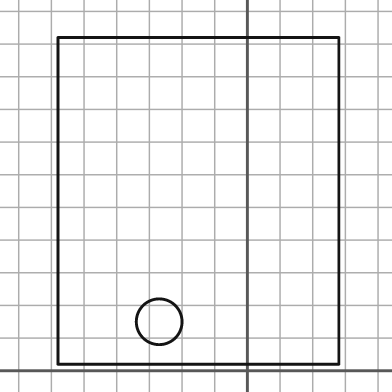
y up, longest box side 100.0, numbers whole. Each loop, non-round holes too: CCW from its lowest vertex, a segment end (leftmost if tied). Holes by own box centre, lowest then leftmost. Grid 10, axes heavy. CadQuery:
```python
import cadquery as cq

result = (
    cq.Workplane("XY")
    .moveTo(-58.0, 2.0)
    .lineTo(28.0, 2.0)
    .lineTo(28.0, 102.0)
    .lineTo(-58.0, 102.0)
    .close()
    .moveTo(-27.0, 15.0)
    .circle(7.0)
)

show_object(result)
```